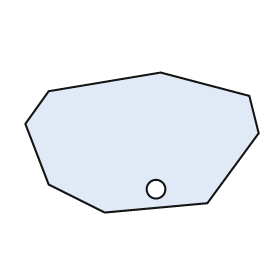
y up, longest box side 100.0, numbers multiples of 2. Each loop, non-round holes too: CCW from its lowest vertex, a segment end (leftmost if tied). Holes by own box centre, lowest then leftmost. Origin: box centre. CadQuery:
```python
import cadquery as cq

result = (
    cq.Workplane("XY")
    .moveTo(-16.0, -30.0)
    .lineTo(28.0, -26.0)
    .lineTo(50.0, 4.0)
    .lineTo(46.0, 20.0)
    .lineTo(8.0, 30.0)
    .lineTo(-40.0, 22.0)
    .lineTo(-50.0, 8.0)
    .lineTo(-40.0, -18.0)
    .close()
    .moveTo(6.0, -20.0)
    .circle(4.0)
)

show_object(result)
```